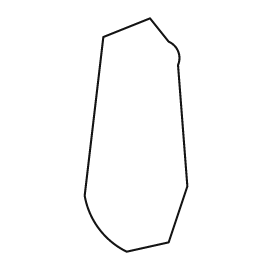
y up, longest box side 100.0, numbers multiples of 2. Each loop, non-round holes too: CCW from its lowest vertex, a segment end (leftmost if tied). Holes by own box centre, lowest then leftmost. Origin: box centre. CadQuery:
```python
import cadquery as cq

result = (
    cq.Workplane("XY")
    .moveTo(-4.0, -50.0)
    .lineTo(14.0, -46.0)
    .lineTo(22.0, -22.0)
    .lineTo(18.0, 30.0)
    .threePointArc((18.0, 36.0), (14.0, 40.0))
    .lineTo(6.0, 50.0)
    .lineTo(-14.0, 42.0)
    .lineTo(-22.0, -26.0)
    .threePointArc((-16.0, -40.0), (-4.0, -50.0))
    .close()
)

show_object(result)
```